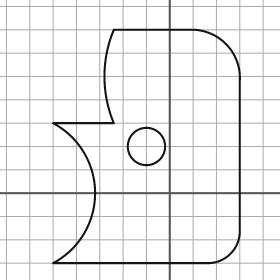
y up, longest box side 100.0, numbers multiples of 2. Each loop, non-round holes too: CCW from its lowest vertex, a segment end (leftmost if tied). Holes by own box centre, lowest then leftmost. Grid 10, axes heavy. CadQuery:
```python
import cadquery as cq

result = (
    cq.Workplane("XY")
    .moveTo(-50.0, -30.0)
    .lineTo(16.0, -30.0)
    .threePointArc((26.0, -26.0), (30.0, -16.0))
    .lineTo(30.0, 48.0)
    .threePointArc((24.0, 64.0), (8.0, 70.0))
    .lineTo(-24.0, 70.0)
    .threePointArc((-28.0, 50.0), (-24.0, 30.0))
    .lineTo(-50.0, 30.0)
    .threePointArc((-32.0, 0.0), (-50.0, -30.0))
    .close()
    .moveTo(-10.0, 20.0)
    .circle(8.0)
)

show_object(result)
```